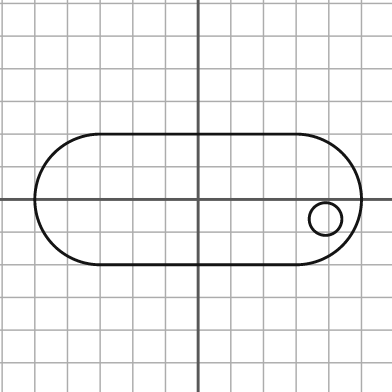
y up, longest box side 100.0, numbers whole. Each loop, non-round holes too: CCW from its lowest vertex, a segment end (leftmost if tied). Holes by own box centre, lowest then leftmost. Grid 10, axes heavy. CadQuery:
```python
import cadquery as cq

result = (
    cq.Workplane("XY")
    .moveTo(-30.0, -20.0)
    .lineTo(30.0, -20.0)
    .threePointArc((50.0, 0.0), (30.0, 20.0))
    .lineTo(-30.0, 20.0)
    .threePointArc((-50.0, 0.0), (-30.0, -20.0))
    .close()
    .moveTo(39.0, -6.0)
    .circle(5.0)
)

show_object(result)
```